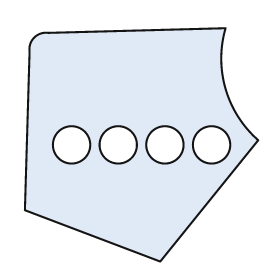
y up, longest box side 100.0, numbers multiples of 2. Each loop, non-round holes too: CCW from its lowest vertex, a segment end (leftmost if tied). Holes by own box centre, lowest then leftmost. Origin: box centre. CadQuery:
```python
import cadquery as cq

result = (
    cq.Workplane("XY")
    .moveTo(8.0, -50.0)
    .lineTo(50.0, 2.0)
    .threePointArc((36.0, 24.0), (36.0, 50.0))
    .lineTo(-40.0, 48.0)
    .threePointArc((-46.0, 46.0), (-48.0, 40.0))
    .lineTo(-50.0, -28.0)
    .close()
    .moveTo(-30.0, 0.0)
    .circle(8.0)
    .moveTo(-10.0, 0.0)
    .circle(8.0)
    .moveTo(10.0, 0.0)
    .circle(8.0)
    .moveTo(30.0, 0.0)
    .circle(8.0)
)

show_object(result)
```